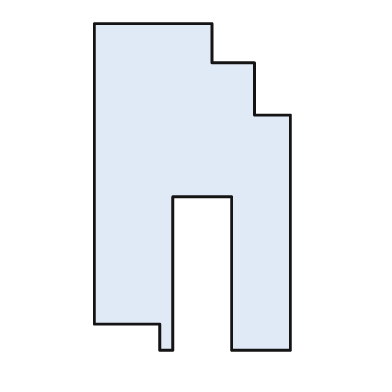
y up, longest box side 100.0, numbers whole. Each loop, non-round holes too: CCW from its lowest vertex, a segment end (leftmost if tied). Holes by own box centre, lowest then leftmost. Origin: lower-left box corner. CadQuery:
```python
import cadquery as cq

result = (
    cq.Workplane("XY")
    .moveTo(20.0, 0.0)
    .lineTo(24.0, 0.0)
    .lineTo(24.0, 47.0)
    .lineTo(42.0, 47.0)
    .lineTo(42.0, 0.0)
    .lineTo(60.0, 0.0)
    .lineTo(60.0, 72.0)
    .lineTo(49.0, 72.0)
    .lineTo(49.0, 88.0)
    .lineTo(36.0, 88.0)
    .lineTo(36.0, 100.0)
    .lineTo(0.0, 100.0)
    .lineTo(0.0, 8.0)
    .lineTo(20.0, 8.0)
    .close()
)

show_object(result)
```